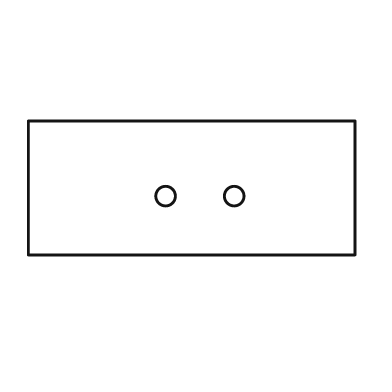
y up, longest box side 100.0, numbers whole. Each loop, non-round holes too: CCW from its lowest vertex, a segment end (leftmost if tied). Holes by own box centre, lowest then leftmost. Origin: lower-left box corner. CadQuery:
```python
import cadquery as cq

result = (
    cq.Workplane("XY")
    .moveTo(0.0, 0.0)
    .lineTo(100.0, 0.0)
    .lineTo(100.0, 41.0)
    .lineTo(0.0, 41.0)
    .close()
    .moveTo(42.0, 18.0)
    .circle(3.0)
    .moveTo(63.0, 18.0)
    .circle(3.0)
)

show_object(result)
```